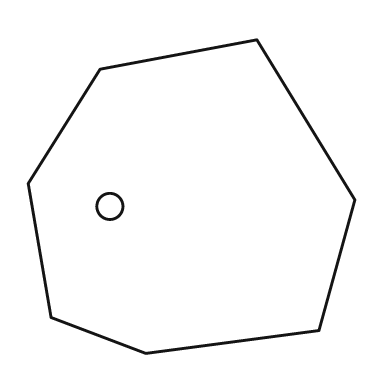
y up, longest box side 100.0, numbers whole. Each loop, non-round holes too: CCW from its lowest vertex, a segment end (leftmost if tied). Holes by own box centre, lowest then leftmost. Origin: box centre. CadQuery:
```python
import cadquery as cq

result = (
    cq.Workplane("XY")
    .moveTo(-14.0, -48.0)
    .lineTo(39.0, -41.0)
    .lineTo(50.0, -1.0)
    .lineTo(20.0, 48.0)
    .lineTo(-28.0, 39.0)
    .lineTo(-50.0, 4.0)
    .lineTo(-43.0, -37.0)
    .close()
    .moveTo(-25.0, -3.0)
    .circle(4.0)
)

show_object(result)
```